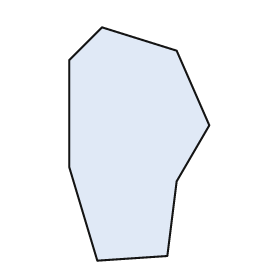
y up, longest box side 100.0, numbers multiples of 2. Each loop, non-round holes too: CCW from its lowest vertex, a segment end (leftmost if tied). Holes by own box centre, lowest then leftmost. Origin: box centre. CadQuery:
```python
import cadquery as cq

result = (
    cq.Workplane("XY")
    .moveTo(-18.0, -50.0)
    .lineTo(12.0, -48.0)
    .lineTo(16.0, -16.0)
    .lineTo(30.0, 8.0)
    .lineTo(16.0, 40.0)
    .lineTo(-16.0, 50.0)
    .lineTo(-30.0, 36.0)
    .lineTo(-30.0, -10.0)
    .close()
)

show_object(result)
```